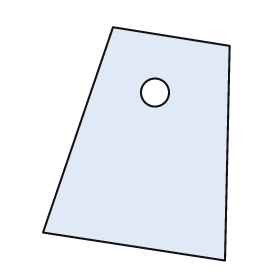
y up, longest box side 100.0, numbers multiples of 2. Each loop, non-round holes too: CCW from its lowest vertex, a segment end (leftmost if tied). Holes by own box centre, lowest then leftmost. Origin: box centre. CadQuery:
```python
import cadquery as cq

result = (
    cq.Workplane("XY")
    .moveTo(38.0, -50.0)
    .lineTo(40.0, 42.0)
    .lineTo(-10.0, 50.0)
    .lineTo(-40.0, -38.0)
    .close()
    .moveTo(8.0, 22.0)
    .circle(6.0)
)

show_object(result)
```